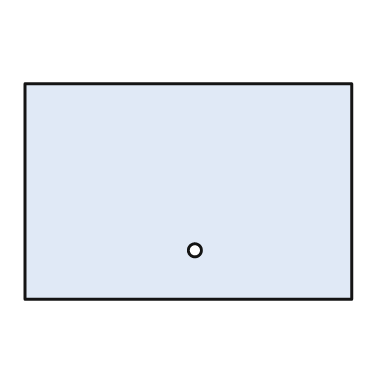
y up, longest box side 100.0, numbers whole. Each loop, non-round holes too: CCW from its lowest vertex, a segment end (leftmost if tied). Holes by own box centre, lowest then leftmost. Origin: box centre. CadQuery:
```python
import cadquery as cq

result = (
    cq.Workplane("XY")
    .moveTo(-50.0, -33.0)
    .lineTo(50.0, -33.0)
    .lineTo(50.0, 33.0)
    .lineTo(-50.0, 33.0)
    .close()
    .moveTo(2.0, -18.0)
    .circle(2.0)
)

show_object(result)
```